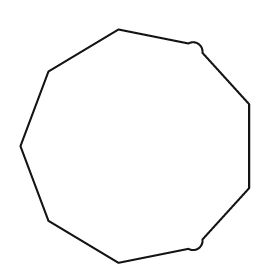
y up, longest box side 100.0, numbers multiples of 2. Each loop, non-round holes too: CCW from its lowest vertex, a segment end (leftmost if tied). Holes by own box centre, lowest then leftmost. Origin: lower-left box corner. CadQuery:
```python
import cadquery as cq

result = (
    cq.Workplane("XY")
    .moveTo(42.0, 0.0)
    .lineTo(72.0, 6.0)
    .threePointArc((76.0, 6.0), (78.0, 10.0))
    .lineTo(98.0, 32.0)
    .lineTo(98.0, 68.0)
    .lineTo(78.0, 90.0)
    .threePointArc((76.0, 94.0), (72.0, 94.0))
    .lineTo(42.0, 100.0)
    .lineTo(12.0, 82.0)
    .lineTo(0.0, 50.0)
    .lineTo(12.0, 18.0)
    .close()
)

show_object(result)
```